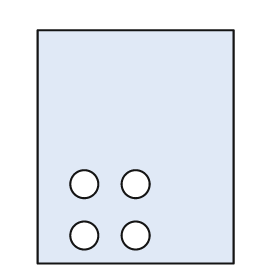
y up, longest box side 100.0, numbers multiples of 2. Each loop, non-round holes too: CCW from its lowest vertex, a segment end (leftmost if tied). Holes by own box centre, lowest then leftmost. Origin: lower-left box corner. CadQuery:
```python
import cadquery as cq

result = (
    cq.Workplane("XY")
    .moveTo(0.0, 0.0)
    .lineTo(84.0, 0.0)
    .lineTo(84.0, 100.0)
    .lineTo(0.0, 100.0)
    .close()
    .moveTo(20.0, 12.0)
    .circle(6.0)
    .moveTo(42.0, 12.0)
    .circle(6.0)
    .moveTo(20.0, 34.0)
    .circle(6.0)
    .moveTo(42.0, 34.0)
    .circle(6.0)
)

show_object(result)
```